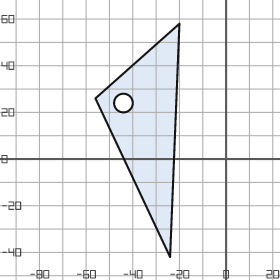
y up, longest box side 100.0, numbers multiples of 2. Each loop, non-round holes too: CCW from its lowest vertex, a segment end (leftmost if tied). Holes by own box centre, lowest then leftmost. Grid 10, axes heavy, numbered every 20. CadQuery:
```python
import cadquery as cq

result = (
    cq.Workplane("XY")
    .moveTo(-24.0, -42.0)
    .lineTo(-20.0, 58.0)
    .lineTo(-56.0, 26.0)
    .close()
    .moveTo(-44.0, 24.0)
    .circle(4.0)
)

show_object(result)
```